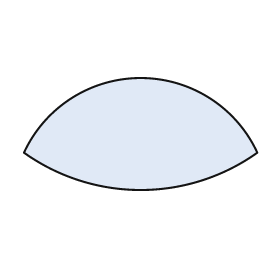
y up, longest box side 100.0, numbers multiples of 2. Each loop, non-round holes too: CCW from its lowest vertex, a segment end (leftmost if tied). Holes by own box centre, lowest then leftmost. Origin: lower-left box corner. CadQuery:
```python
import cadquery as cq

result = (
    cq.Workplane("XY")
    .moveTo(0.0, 16.0)
    .threePointArc((50.0, 0.0), (100.0, 16.0))
    .threePointArc((50.0, 48.0), (0.0, 16.0))
    .close()
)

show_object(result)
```